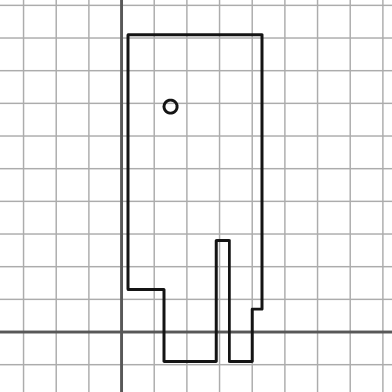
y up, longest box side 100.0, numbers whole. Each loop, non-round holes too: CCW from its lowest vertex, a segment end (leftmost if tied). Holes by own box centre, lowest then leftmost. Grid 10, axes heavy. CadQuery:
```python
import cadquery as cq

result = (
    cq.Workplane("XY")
    .moveTo(13.0, -9.0)
    .lineTo(29.0, -9.0)
    .lineTo(29.0, 28.0)
    .lineTo(33.0, 28.0)
    .lineTo(33.0, -9.0)
    .lineTo(40.0, -9.0)
    .lineTo(40.0, 7.0)
    .lineTo(43.0, 7.0)
    .lineTo(43.0, 91.0)
    .lineTo(2.0, 91.0)
    .lineTo(2.0, 13.0)
    .lineTo(13.0, 13.0)
    .close()
    .moveTo(15.0, 69.0)
    .circle(2.0)
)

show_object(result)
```